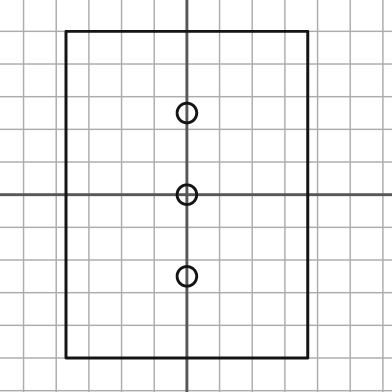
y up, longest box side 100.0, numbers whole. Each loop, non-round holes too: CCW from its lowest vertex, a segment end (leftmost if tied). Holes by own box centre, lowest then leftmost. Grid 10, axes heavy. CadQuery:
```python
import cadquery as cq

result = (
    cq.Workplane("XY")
    .moveTo(-37.0, -50.0)
    .lineTo(37.0, -50.0)
    .lineTo(37.0, 50.0)
    .lineTo(-37.0, 50.0)
    .close()
    .moveTo(0.0, -25.0)
    .circle(3.0)
    .moveTo(0.0, 0.0)
    .circle(3.0)
    .moveTo(0.0, 25.0)
    .circle(3.0)
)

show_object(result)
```